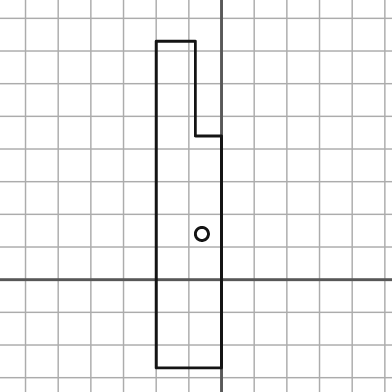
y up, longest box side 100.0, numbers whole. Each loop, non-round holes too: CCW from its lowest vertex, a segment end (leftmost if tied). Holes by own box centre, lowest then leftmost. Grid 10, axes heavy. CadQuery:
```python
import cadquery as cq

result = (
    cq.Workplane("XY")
    .moveTo(-20.0, -27.0)
    .lineTo(0.0, -27.0)
    .lineTo(0.0, 44.0)
    .lineTo(-8.0, 44.0)
    .lineTo(-8.0, 73.0)
    .lineTo(-20.0, 73.0)
    .close()
    .moveTo(-6.0, 14.0)
    .circle(2.0)
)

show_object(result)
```